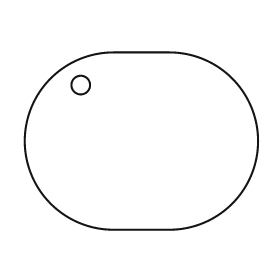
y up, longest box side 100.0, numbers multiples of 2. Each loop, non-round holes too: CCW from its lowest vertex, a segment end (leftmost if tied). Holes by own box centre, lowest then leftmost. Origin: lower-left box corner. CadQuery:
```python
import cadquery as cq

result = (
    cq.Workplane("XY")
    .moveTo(38.0, 0.0)
    .lineTo(62.0, 0.0)
    .threePointArc((100.0, 38.0), (62.0, 76.0))
    .lineTo(38.0, 76.0)
    .threePointArc((0.0, 38.0), (38.0, 0.0))
    .close()
    .moveTo(24.0, 62.0)
    .circle(4.0)
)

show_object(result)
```